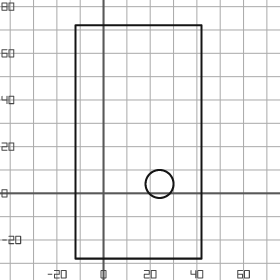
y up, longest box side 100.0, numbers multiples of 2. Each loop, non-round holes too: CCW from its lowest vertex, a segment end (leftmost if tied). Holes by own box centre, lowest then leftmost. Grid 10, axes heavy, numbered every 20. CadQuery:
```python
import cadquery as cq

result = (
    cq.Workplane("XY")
    .moveTo(-12.0, -28.0)
    .lineTo(42.0, -28.0)
    .lineTo(42.0, 72.0)
    .lineTo(-12.0, 72.0)
    .close()
    .moveTo(24.0, 4.0)
    .circle(6.0)
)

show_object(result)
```